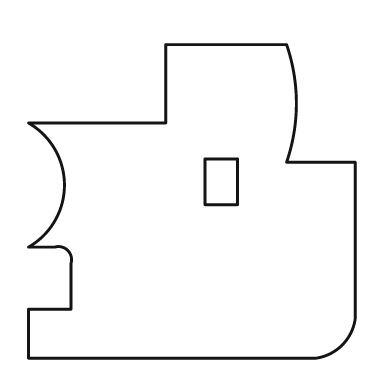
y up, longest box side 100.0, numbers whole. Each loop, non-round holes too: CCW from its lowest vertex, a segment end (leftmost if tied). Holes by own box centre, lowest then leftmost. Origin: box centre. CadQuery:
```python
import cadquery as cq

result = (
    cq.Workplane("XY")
    .moveTo(-50.0, -48.0)
    .lineTo(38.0, -48.0)
    .threePointArc((46.0, -44.0), (50.0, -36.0))
    .lineTo(50.0, 12.0)
    .lineTo(29.0, 12.0)
    .threePointArc((32.0, 30.0), (29.0, 48.0))
    .lineTo(-8.0, 48.0)
    .lineTo(-8.0, 24.0)
    .lineTo(-50.0, 24.0)
    .threePointArc((-39.0, 5.0), (-50.0, -14.0))
    .lineTo(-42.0, -14.0)
    .threePointArc((-38.0, -15.0), (-37.0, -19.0))
    .lineTo(-37.0, -33.0)
    .lineTo(-50.0, -33.0)
    .close()
    .moveTo(4.0, -1.0)
    .lineTo(14.0, -1.0)
    .lineTo(14.0, 13.0)
    .lineTo(4.0, 13.0)
    .close()
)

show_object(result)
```